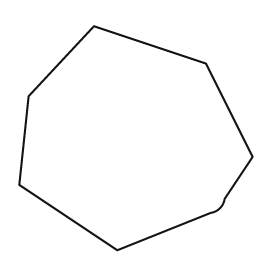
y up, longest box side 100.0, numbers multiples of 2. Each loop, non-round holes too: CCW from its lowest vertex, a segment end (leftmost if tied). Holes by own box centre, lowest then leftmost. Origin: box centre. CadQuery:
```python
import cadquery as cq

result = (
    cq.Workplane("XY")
    .moveTo(-8.0, -48.0)
    .lineTo(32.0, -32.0)
    .threePointArc((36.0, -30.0), (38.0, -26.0))
    .lineTo(50.0, -8.0)
    .lineTo(30.0, 32.0)
    .lineTo(-18.0, 48.0)
    .lineTo(-46.0, 18.0)
    .lineTo(-50.0, -20.0)
    .close()
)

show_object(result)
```